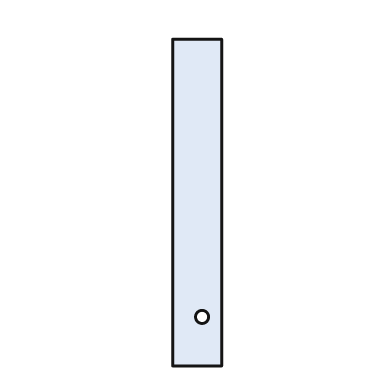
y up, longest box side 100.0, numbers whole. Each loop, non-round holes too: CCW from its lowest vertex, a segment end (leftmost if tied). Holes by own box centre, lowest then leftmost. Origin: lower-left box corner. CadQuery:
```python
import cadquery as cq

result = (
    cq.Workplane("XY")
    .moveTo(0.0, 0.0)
    .lineTo(15.0, 0.0)
    .lineTo(15.0, 100.0)
    .lineTo(0.0, 100.0)
    .close()
    .moveTo(9.0, 15.0)
    .circle(2.0)
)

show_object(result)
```